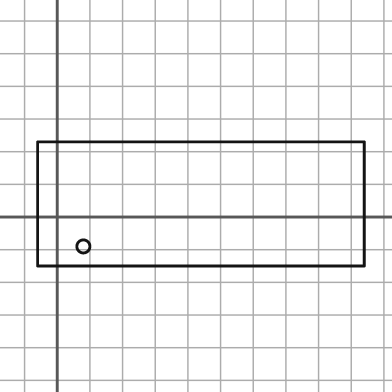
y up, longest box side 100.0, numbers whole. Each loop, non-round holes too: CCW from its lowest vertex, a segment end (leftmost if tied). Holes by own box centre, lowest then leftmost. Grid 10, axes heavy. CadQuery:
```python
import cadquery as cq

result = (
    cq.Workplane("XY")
    .moveTo(-6.0, -15.0)
    .lineTo(94.0, -15.0)
    .lineTo(94.0, 23.0)
    .lineTo(-6.0, 23.0)
    .close()
    .moveTo(8.0, -9.0)
    .circle(2.0)
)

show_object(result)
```